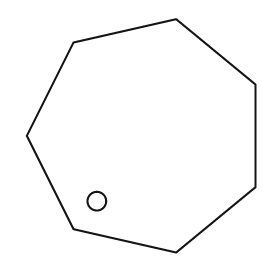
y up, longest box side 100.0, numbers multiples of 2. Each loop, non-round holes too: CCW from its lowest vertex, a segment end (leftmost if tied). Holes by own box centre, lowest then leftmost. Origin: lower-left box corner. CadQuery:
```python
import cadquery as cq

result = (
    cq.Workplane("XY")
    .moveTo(64.0, 0.0)
    .lineTo(98.0, 28.0)
    .lineTo(98.0, 72.0)
    .lineTo(64.0, 100.0)
    .lineTo(20.0, 90.0)
    .lineTo(0.0, 50.0)
    .lineTo(20.0, 10.0)
    .close()
    .moveTo(30.0, 22.0)
    .circle(4.0)
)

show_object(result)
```